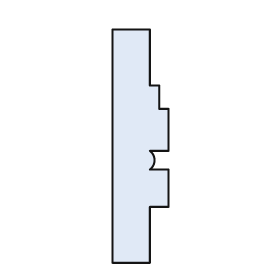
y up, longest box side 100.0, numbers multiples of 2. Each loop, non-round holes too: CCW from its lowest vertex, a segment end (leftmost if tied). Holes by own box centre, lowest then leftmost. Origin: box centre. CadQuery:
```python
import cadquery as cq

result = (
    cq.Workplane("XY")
    .moveTo(-12.0, -50.0)
    .lineTo(4.0, -50.0)
    .lineTo(4.0, -26.0)
    .lineTo(12.0, -26.0)
    .lineTo(12.0, -10.0)
    .lineTo(4.0, -10.0)
    .threePointArc((6.0, -6.0), (4.0, -2.0))
    .lineTo(12.0, -2.0)
    .lineTo(12.0, 16.0)
    .lineTo(8.0, 16.0)
    .lineTo(8.0, 26.0)
    .lineTo(4.0, 26.0)
    .lineTo(4.0, 50.0)
    .lineTo(-12.0, 50.0)
    .close()
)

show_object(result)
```